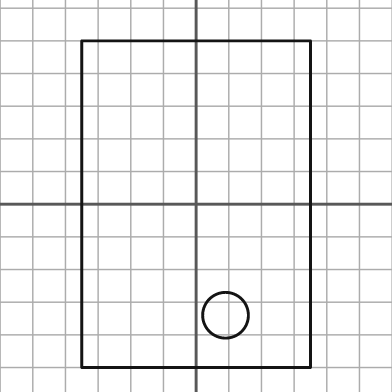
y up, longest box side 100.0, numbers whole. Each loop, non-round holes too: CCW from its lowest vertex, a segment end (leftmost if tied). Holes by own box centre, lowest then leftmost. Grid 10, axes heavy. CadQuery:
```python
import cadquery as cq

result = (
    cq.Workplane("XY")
    .moveTo(-35.0, -50.0)
    .lineTo(35.0, -50.0)
    .lineTo(35.0, 50.0)
    .lineTo(-35.0, 50.0)
    .close()
    .moveTo(9.0, -34.0)
    .circle(7.0)
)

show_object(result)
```